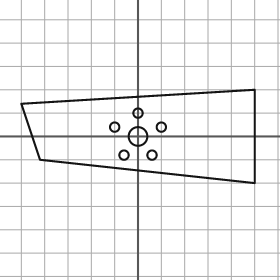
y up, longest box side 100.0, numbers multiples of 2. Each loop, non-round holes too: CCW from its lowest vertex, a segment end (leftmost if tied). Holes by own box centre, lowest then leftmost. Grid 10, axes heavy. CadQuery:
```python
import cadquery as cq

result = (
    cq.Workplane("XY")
    .moveTo(50.0, -20.0)
    .lineTo(50.0, 20.0)
    .lineTo(-50.0, 14.0)
    .lineTo(-42.0, -10.0)
    .close()
    .moveTo(-6.0, -8.0)
    .circle(2.0)
    .moveTo(6.0, -8.0)
    .circle(2.0)
    .moveTo(0.0, 0.0)
    .circle(4.0)
    .moveTo(-10.0, 4.0)
    .circle(2.0)
    .moveTo(10.0, 4.0)
    .circle(2.0)
    .moveTo(0.0, 10.0)
    .circle(2.0)
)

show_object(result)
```